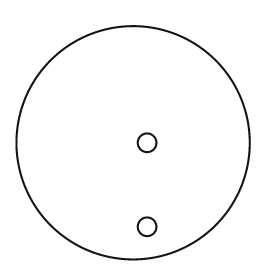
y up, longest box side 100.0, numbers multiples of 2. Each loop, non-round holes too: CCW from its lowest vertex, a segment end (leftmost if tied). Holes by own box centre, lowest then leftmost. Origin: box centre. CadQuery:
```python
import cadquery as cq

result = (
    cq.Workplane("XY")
    .moveTo(0.0, 0.0)
    .circle(50.0)
    .moveTo(6.0, -36.0)
    .circle(4.0)
    .moveTo(6.0, 0.0)
    .circle(4.0)
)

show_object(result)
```